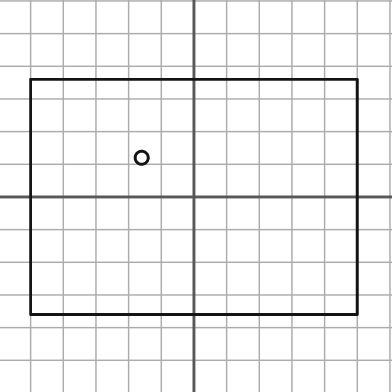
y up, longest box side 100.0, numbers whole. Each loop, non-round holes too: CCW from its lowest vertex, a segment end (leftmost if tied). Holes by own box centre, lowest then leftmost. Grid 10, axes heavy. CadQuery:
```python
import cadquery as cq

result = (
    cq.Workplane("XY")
    .moveTo(-50.0, -36.0)
    .lineTo(50.0, -36.0)
    .lineTo(50.0, 36.0)
    .lineTo(-50.0, 36.0)
    .close()
    .moveTo(-16.0, 12.0)
    .circle(2.0)
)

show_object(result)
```